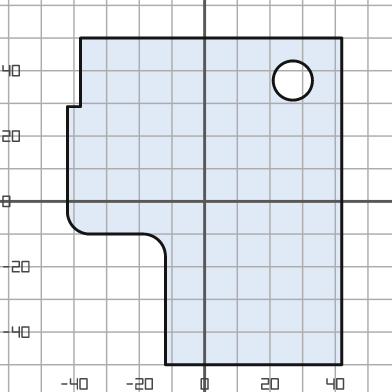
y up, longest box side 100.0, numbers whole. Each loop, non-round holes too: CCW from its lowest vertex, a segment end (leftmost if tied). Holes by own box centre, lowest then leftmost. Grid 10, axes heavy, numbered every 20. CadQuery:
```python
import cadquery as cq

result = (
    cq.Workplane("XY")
    .moveTo(-12.0, -50.0)
    .lineTo(42.0, -50.0)
    .lineTo(42.0, 50.0)
    .lineTo(-38.0, 50.0)
    .lineTo(-38.0, 29.0)
    .lineTo(-42.0, 29.0)
    .lineTo(-42.0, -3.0)
    .threePointArc((-40.0, -8.0), (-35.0, -10.0))
    .lineTo(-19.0, -10.0)
    .threePointArc((-14.0, -12.0), (-12.0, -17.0))
    .close()
    .moveTo(27.0, 37.0)
    .circle(6.0)
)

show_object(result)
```